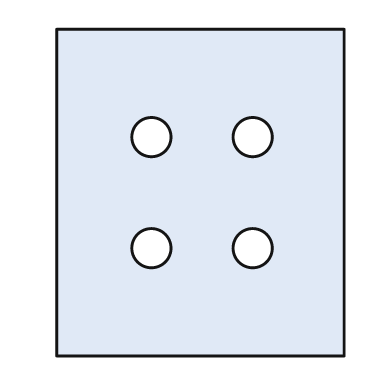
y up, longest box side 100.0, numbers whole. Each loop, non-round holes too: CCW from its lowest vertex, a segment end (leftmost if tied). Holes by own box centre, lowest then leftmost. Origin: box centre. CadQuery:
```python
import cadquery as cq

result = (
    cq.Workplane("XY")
    .moveTo(-44.0, -50.0)
    .lineTo(44.0, -50.0)
    .lineTo(44.0, 50.0)
    .lineTo(-44.0, 50.0)
    .close()
    .moveTo(-15.0, -17.0)
    .circle(6.0)
    .moveTo(16.0, -17.0)
    .circle(6.0)
    .moveTo(-15.0, 17.0)
    .circle(6.0)
    .moveTo(16.0, 17.0)
    .circle(6.0)
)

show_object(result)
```